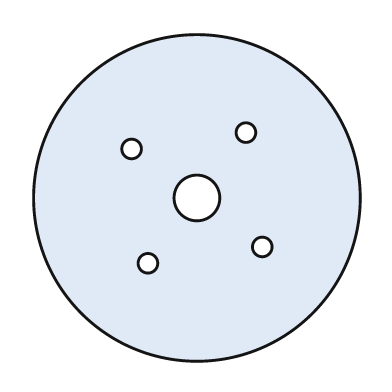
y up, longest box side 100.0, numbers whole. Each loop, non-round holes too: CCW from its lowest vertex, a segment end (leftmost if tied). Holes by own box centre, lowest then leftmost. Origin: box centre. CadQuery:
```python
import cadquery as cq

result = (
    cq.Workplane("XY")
    .moveTo(0.0, 0.0)
    .circle(50.0)
    .moveTo(-15.0, -20.0)
    .circle(3.0)
    .moveTo(20.0, -15.0)
    .circle(3.0)
    .moveTo(0.0, 0.0)
    .circle(7.0)
    .moveTo(-20.0, 15.0)
    .circle(3.0)
    .moveTo(15.0, 20.0)
    .circle(3.0)
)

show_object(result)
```